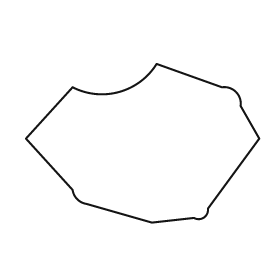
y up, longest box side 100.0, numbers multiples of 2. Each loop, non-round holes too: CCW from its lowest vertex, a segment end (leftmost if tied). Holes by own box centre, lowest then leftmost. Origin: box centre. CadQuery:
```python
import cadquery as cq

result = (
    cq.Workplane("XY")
    .moveTo(4.0, -34.0)
    .lineTo(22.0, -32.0)
    .threePointArc((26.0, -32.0), (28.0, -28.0))
    .lineTo(50.0, 2.0)
    .lineTo(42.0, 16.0)
    .threePointArc((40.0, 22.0), (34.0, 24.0))
    .lineTo(6.0, 34.0)
    .threePointArc((-10.0, 22.0), (-30.0, 24.0))
    .lineTo(-50.0, 2.0)
    .lineTo(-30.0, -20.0)
    .threePointArc((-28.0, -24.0), (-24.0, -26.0))
    .close()
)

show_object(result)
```